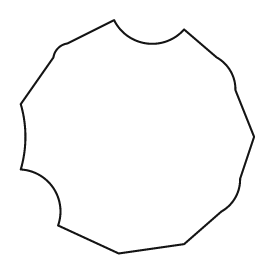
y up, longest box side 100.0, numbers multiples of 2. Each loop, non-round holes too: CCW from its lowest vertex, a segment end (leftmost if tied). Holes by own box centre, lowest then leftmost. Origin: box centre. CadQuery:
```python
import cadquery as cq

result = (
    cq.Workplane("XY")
    .moveTo(-8.0, -50.0)
    .lineTo(20.0, -46.0)
    .lineTo(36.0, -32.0)
    .threePointArc((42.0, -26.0), (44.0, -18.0))
    .lineTo(50.0, 0.0)
    .lineTo(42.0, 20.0)
    .threePointArc((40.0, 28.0), (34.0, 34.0))
    .lineTo(20.0, 46.0)
    .threePointArc((4.0, 40.0), (-10.0, 50.0))
    .lineTo(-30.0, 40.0)
    .threePointArc((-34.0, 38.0), (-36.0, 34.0))
    .lineTo(-50.0, 14.0)
    .threePointArc((-48.0, 0.0), (-50.0, -14.0))
    .threePointArc((-36.0, -22.0), (-34.0, -38.0))
    .close()
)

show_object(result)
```